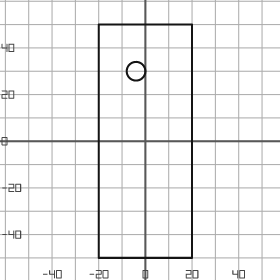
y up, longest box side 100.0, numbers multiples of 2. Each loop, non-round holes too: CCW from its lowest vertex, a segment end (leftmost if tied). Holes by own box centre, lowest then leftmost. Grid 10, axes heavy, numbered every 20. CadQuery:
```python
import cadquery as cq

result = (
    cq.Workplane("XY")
    .moveTo(-20.0, -50.0)
    .lineTo(20.0, -50.0)
    .lineTo(20.0, 50.0)
    .lineTo(-20.0, 50.0)
    .close()
    .moveTo(-4.0, 30.0)
    .circle(4.0)
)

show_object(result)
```